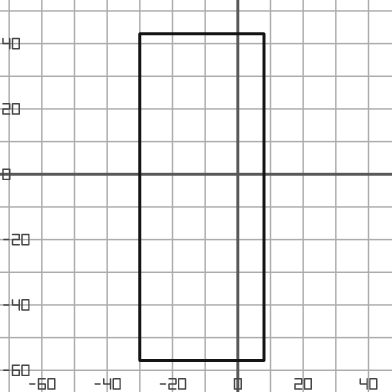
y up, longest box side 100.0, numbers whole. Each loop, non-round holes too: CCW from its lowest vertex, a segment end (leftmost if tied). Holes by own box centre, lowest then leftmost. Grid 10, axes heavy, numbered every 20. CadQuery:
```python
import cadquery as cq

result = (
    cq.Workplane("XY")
    .moveTo(-30.0, -57.0)
    .lineTo(8.0, -57.0)
    .lineTo(8.0, 43.0)
    .lineTo(-30.0, 43.0)
    .close()
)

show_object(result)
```